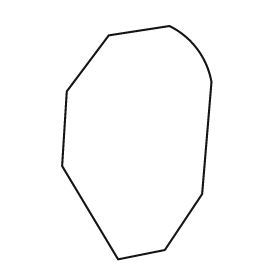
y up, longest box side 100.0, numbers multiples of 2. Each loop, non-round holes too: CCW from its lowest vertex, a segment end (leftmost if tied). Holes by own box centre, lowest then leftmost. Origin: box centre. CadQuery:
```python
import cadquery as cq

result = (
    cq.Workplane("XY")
    .moveTo(-8.0, -50.0)
    .lineTo(12.0, -46.0)
    .lineTo(28.0, -22.0)
    .lineTo(32.0, 26.0)
    .threePointArc((26.0, 40.0), (14.0, 50.0))
    .lineTo(-12.0, 46.0)
    .lineTo(-30.0, 22.0)
    .lineTo(-32.0, -10.0)
    .close()
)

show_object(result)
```